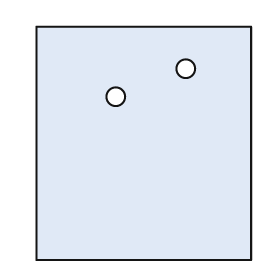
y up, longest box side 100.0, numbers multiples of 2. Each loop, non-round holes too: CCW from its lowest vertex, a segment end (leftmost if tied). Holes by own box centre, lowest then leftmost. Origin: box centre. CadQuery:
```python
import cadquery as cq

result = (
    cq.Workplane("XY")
    .moveTo(-46.0, -50.0)
    .lineTo(46.0, -50.0)
    .lineTo(46.0, 50.0)
    .lineTo(-46.0, 50.0)
    .close()
    .moveTo(-12.0, 20.0)
    .circle(4.0)
    .moveTo(18.0, 32.0)
    .circle(4.0)
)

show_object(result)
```